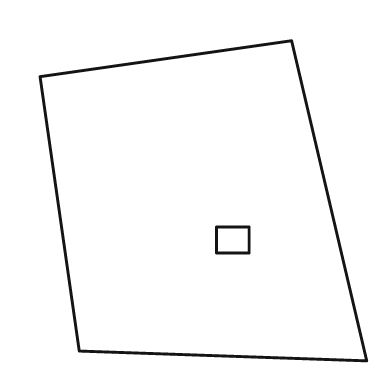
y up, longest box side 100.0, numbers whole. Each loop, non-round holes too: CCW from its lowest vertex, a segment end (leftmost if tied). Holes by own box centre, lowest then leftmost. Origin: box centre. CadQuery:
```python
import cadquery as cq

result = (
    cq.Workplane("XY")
    .moveTo(50.0, -49.0)
    .lineTo(27.0, 49.0)
    .lineTo(-50.0, 38.0)
    .lineTo(-38.0, -46.0)
    .close()
    .moveTo(4.0, -16.0)
    .lineTo(14.0, -16.0)
    .lineTo(14.0, -8.0)
    .lineTo(4.0, -8.0)
    .close()
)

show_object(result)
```